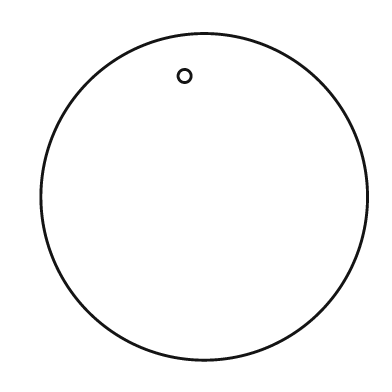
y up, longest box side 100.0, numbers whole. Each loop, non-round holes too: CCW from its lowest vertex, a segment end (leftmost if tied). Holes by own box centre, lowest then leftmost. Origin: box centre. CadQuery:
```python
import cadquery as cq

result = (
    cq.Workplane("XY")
    .moveTo(0.0, 0.0)
    .circle(50.0)
    .moveTo(-6.0, 37.0)
    .circle(2.0)
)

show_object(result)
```